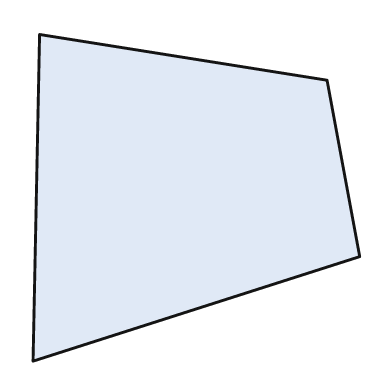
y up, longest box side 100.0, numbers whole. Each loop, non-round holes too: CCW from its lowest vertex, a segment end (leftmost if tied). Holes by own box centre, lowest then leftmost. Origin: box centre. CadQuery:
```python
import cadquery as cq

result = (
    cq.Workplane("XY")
    .moveTo(-50.0, -50.0)
    .lineTo(50.0, -18.0)
    .lineTo(40.0, 36.0)
    .lineTo(-48.0, 50.0)
    .close()
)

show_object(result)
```